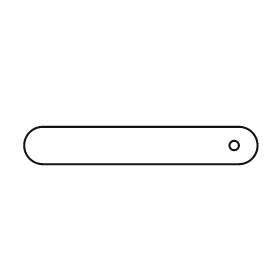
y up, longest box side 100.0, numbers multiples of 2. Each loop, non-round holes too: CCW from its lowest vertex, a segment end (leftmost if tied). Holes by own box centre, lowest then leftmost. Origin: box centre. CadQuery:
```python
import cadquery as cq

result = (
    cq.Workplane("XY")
    .moveTo(-42.0, -8.0)
    .lineTo(42.0, -8.0)
    .threePointArc((50.0, 0.0), (42.0, 8.0))
    .lineTo(-42.0, 8.0)
    .threePointArc((-50.0, 0.0), (-42.0, -8.0))
    .close()
    .moveTo(40.0, 0.0)
    .circle(2.0)
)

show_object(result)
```